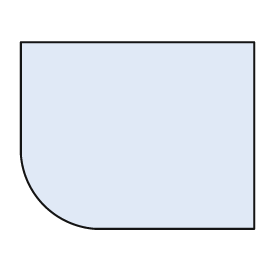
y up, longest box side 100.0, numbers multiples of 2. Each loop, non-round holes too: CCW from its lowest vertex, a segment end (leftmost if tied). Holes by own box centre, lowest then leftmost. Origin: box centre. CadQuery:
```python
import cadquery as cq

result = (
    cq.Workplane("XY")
    .moveTo(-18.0, -40.0)
    .lineTo(50.0, -40.0)
    .lineTo(50.0, 40.0)
    .lineTo(-50.0, 40.0)
    .lineTo(-50.0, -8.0)
    .threePointArc((-40.0, -30.0), (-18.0, -40.0))
    .close()
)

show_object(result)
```